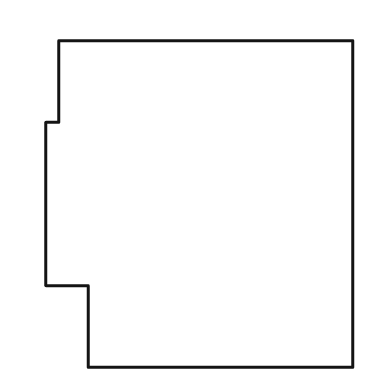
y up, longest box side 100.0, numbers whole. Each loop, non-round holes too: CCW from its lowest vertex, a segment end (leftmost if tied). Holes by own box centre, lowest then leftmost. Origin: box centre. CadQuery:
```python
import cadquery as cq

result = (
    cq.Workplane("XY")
    .moveTo(-34.0, -50.0)
    .lineTo(47.0, -50.0)
    .lineTo(47.0, 50.0)
    .lineTo(-43.0, 50.0)
    .lineTo(-43.0, 25.0)
    .lineTo(-47.0, 25.0)
    .lineTo(-47.0, -25.0)
    .lineTo(-34.0, -25.0)
    .close()
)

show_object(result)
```